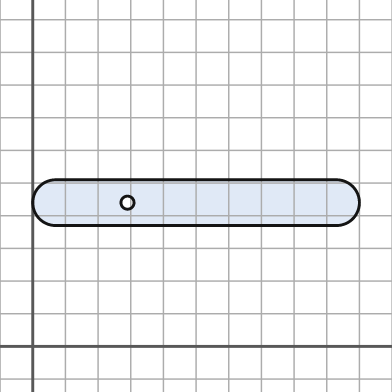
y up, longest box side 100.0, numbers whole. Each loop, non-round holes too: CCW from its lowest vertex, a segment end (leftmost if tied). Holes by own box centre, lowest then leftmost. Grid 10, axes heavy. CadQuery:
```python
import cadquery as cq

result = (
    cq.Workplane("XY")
    .moveTo(7.0, 37.0)
    .lineTo(93.0, 37.0)
    .threePointArc((100.0, 44.0), (93.0, 51.0))
    .lineTo(7.0, 51.0)
    .threePointArc((0.0, 44.0), (7.0, 37.0))
    .close()
    .moveTo(29.0, 44.0)
    .circle(2.0)
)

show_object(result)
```